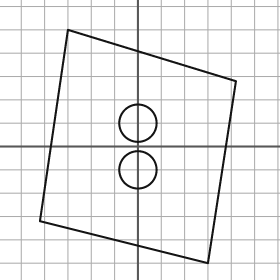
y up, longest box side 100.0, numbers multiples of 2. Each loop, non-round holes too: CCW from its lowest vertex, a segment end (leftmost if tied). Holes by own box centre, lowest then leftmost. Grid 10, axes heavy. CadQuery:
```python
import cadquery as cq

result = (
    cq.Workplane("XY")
    .moveTo(30.0, -50.0)
    .lineTo(42.0, 28.0)
    .lineTo(-30.0, 50.0)
    .lineTo(-42.0, -32.0)
    .close()
    .moveTo(0.0, -10.0)
    .circle(8.0)
    .moveTo(0.0, 10.0)
    .circle(8.0)
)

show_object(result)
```